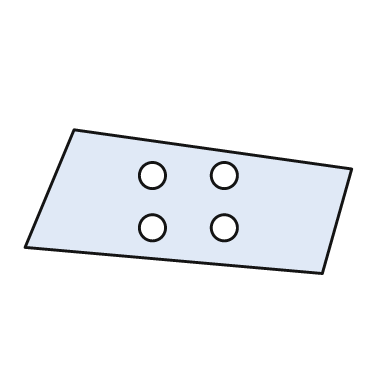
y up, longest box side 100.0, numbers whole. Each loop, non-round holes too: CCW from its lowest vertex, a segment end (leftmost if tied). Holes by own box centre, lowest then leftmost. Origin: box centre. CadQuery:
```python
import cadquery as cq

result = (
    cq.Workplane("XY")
    .moveTo(41.0, -22.0)
    .lineTo(50.0, 10.0)
    .lineTo(-35.0, 22.0)
    .lineTo(-50.0, -14.0)
    .close()
    .moveTo(-11.0, -8.0)
    .circle(4.0)
    .moveTo(11.0, -8.0)
    .circle(4.0)
    .moveTo(-11.0, 8.0)
    .circle(4.0)
    .moveTo(11.0, 8.0)
    .circle(4.0)
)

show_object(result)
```